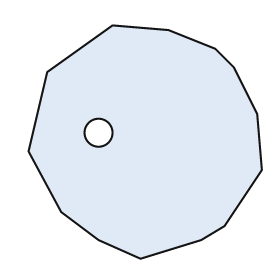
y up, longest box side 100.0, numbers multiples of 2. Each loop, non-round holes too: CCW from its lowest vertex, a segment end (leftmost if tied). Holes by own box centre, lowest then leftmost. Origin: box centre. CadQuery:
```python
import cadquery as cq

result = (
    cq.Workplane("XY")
    .moveTo(-2.0, -50.0)
    .lineTo(24.0, -42.0)
    .lineTo(34.0, -36.0)
    .lineTo(50.0, -12.0)
    .lineTo(48.0, 12.0)
    .lineTo(38.0, 32.0)
    .lineTo(30.0, 40.0)
    .lineTo(10.0, 48.0)
    .lineTo(-14.0, 50.0)
    .lineTo(-42.0, 30.0)
    .lineTo(-50.0, -4.0)
    .lineTo(-36.0, -30.0)
    .lineTo(-20.0, -42.0)
    .close()
    .moveTo(-20.0, 4.0)
    .circle(6.0)
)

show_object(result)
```